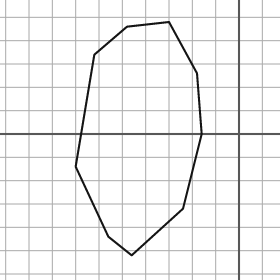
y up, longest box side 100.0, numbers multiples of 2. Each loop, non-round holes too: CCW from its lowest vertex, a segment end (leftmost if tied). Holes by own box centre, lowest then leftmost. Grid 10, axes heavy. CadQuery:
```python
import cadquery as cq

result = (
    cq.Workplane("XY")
    .moveTo(-46.0, -52.0)
    .lineTo(-24.0, -32.0)
    .lineTo(-16.0, 0.0)
    .lineTo(-18.0, 26.0)
    .lineTo(-30.0, 48.0)
    .lineTo(-48.0, 46.0)
    .lineTo(-62.0, 34.0)
    .lineTo(-70.0, -14.0)
    .lineTo(-56.0, -44.0)
    .close()
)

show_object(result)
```